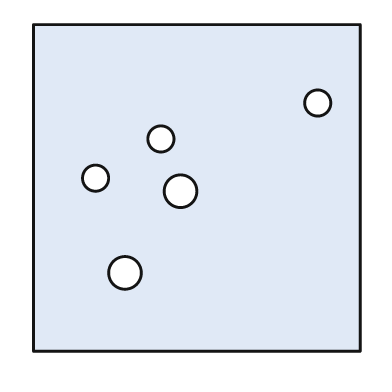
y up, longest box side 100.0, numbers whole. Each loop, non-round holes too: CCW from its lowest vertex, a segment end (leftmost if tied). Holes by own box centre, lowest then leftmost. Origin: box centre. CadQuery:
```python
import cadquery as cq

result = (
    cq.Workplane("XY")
    .moveTo(-50.0, -50.0)
    .lineTo(50.0, -50.0)
    .lineTo(50.0, 50.0)
    .lineTo(-50.0, 50.0)
    .close()
    .moveTo(-22.0, -26.0)
    .circle(5.0)
    .moveTo(-5.0, -1.0)
    .circle(5.0)
    .moveTo(-31.0, 3.0)
    .circle(4.0)
    .moveTo(-11.0, 15.0)
    .circle(4.0)
    .moveTo(37.0, 26.0)
    .circle(4.0)
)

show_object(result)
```